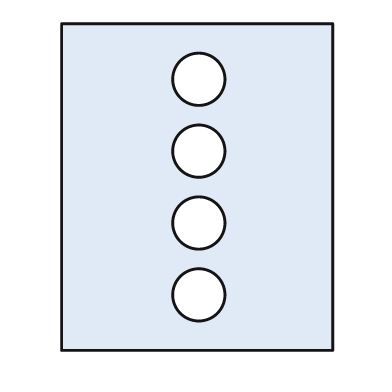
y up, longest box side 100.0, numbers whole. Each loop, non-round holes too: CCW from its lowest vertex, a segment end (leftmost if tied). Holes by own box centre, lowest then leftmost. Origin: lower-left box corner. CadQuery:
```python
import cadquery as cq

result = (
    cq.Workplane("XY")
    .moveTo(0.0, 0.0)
    .lineTo(83.0, 0.0)
    .lineTo(83.0, 100.0)
    .lineTo(0.0, 100.0)
    .close()
    .moveTo(42.0, 17.0)
    .circle(8.0)
    .moveTo(42.0, 39.0)
    .circle(8.0)
    .moveTo(42.0, 61.0)
    .circle(8.0)
    .moveTo(42.0, 83.0)
    .circle(8.0)
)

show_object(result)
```